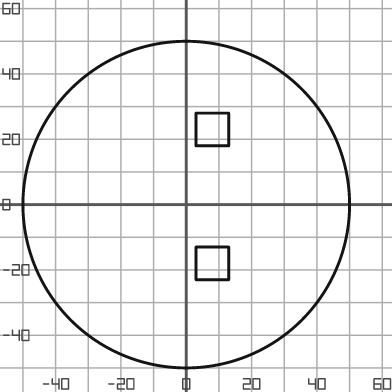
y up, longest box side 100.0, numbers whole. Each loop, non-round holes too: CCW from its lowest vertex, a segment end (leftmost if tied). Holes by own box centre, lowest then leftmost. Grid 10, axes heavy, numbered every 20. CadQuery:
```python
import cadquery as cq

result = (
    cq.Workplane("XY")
    .moveTo(0.0, 0.0)
    .circle(50.0)
    .moveTo(3.0, -23.0)
    .lineTo(13.0, -23.0)
    .lineTo(13.0, -13.0)
    .lineTo(3.0, -13.0)
    .close()
    .moveTo(3.0, 18.0)
    .lineTo(13.0, 18.0)
    .lineTo(13.0, 28.0)
    .lineTo(3.0, 28.0)
    .close()
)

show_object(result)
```